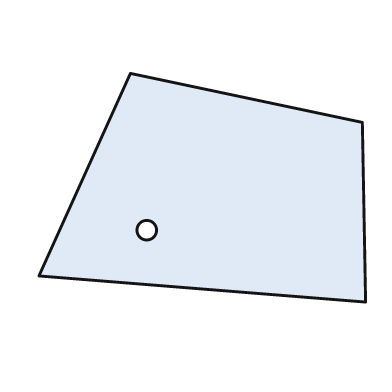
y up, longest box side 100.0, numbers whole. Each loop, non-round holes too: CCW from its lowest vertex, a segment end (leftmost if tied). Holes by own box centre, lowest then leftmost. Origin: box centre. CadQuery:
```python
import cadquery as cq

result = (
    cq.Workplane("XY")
    .moveTo(50.0, -35.0)
    .lineTo(49.0, 20.0)
    .lineTo(-22.0, 35.0)
    .lineTo(-50.0, -27.0)
    .close()
    .moveTo(-17.0, -13.0)
    .circle(3.0)
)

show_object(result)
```